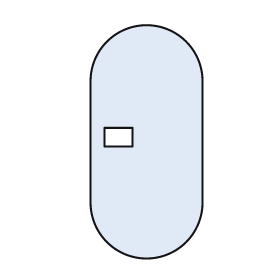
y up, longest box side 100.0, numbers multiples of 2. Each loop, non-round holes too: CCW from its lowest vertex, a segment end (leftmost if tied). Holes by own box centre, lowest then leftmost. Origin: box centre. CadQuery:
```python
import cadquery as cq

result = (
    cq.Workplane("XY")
    .moveTo(-24.0, -26.0)
    .threePointArc((0.0, -50.0), (24.0, -26.0))
    .lineTo(24.0, 26.0)
    .threePointArc((0.0, 50.0), (-24.0, 26.0))
    .close()
    .moveTo(-18.0, -2.0)
    .lineTo(-6.0, -2.0)
    .lineTo(-6.0, 6.0)
    .lineTo(-18.0, 6.0)
    .close()
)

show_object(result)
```